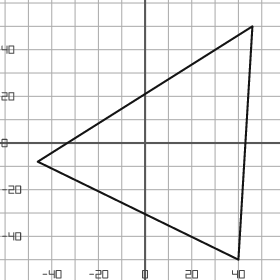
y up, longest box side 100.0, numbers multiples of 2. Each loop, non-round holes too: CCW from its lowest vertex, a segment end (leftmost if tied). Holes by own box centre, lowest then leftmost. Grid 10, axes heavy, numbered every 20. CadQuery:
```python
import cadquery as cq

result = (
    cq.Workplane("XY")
    .moveTo(40.0, -50.0)
    .lineTo(46.0, 50.0)
    .lineTo(-46.0, -8.0)
    .close()
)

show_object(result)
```